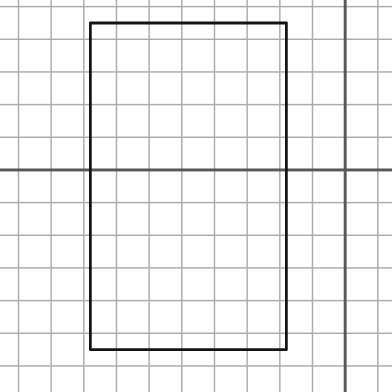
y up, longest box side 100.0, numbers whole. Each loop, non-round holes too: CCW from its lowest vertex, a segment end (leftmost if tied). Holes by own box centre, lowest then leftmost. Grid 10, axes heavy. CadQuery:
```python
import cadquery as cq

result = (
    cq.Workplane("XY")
    .moveTo(-78.0, -55.0)
    .lineTo(-18.0, -55.0)
    .lineTo(-18.0, 45.0)
    .lineTo(-78.0, 45.0)
    .close()
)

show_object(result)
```